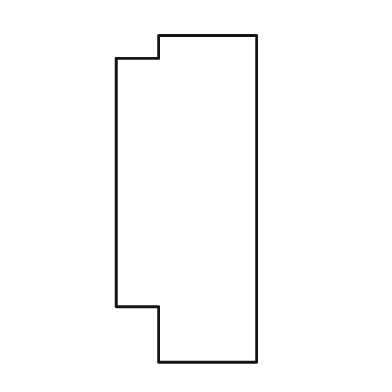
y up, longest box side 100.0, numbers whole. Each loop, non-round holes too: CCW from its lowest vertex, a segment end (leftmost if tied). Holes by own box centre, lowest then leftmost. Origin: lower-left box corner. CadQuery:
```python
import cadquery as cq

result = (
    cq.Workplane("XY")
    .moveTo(13.0, 0.0)
    .lineTo(43.0, 0.0)
    .lineTo(43.0, 100.0)
    .lineTo(13.0, 100.0)
    .lineTo(13.0, 93.0)
    .lineTo(0.0, 93.0)
    .lineTo(0.0, 17.0)
    .lineTo(13.0, 17.0)
    .close()
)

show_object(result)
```